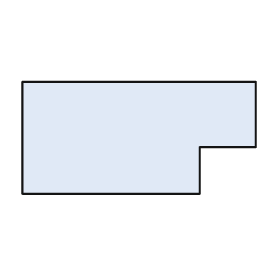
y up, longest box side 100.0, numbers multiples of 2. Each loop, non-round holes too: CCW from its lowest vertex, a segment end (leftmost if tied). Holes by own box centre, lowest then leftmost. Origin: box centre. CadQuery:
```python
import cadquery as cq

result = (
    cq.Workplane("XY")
    .moveTo(-50.0, -24.0)
    .lineTo(26.0, -24.0)
    .lineTo(26.0, -4.0)
    .lineTo(50.0, -4.0)
    .lineTo(50.0, 24.0)
    .lineTo(-50.0, 24.0)
    .close()
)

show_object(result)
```